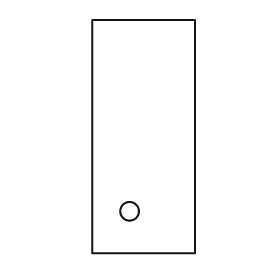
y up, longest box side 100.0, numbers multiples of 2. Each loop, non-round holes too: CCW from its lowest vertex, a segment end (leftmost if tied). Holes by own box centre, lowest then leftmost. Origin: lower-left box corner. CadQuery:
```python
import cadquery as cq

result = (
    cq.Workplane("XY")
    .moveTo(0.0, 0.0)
    .lineTo(44.0, 0.0)
    .lineTo(44.0, 100.0)
    .lineTo(0.0, 100.0)
    .close()
    .moveTo(16.0, 18.0)
    .circle(4.0)
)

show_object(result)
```